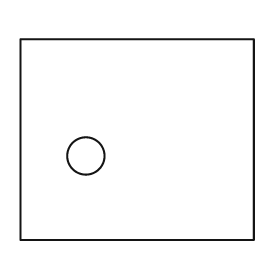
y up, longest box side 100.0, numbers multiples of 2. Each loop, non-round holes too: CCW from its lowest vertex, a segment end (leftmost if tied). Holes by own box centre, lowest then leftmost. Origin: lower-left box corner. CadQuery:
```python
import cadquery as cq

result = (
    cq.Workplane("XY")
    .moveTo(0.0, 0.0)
    .lineTo(100.0, 0.0)
    .lineTo(100.0, 86.0)
    .lineTo(0.0, 86.0)
    .close()
    .moveTo(28.0, 36.0)
    .circle(8.0)
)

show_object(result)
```